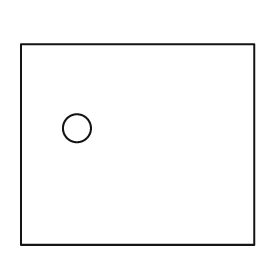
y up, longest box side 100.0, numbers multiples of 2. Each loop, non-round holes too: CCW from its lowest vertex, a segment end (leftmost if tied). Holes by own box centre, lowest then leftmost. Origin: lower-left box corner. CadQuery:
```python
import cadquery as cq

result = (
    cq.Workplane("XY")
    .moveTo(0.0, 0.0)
    .lineTo(100.0, 0.0)
    .lineTo(100.0, 86.0)
    .lineTo(0.0, 86.0)
    .close()
    .moveTo(24.0, 50.0)
    .circle(6.0)
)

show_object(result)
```